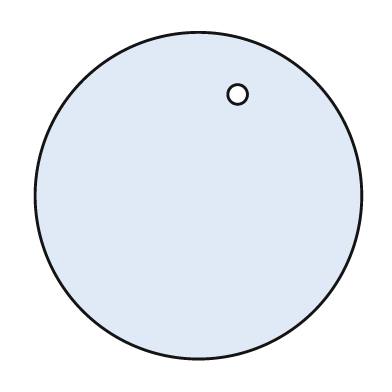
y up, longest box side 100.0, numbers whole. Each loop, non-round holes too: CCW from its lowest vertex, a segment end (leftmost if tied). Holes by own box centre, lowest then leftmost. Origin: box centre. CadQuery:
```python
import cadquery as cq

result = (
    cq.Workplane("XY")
    .moveTo(0.0, 0.0)
    .circle(50.0)
    .moveTo(12.0, 31.0)
    .circle(3.0)
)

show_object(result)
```